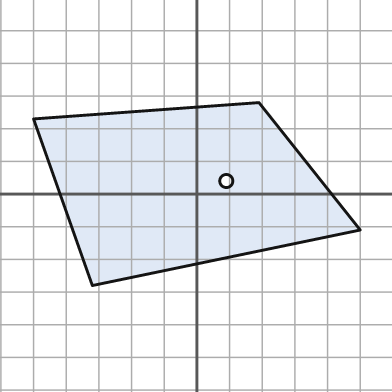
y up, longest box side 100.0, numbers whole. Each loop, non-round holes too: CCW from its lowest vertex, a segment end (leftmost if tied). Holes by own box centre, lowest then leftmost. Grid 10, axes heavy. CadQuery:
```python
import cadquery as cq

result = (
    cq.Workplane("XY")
    .moveTo(-32.0, -28.0)
    .lineTo(50.0, -11.0)
    .lineTo(19.0, 28.0)
    .lineTo(-50.0, 23.0)
    .close()
    .moveTo(9.0, 4.0)
    .circle(2.0)
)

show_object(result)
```